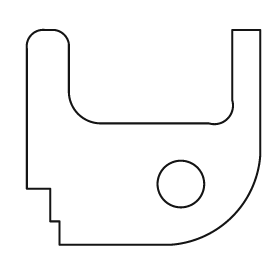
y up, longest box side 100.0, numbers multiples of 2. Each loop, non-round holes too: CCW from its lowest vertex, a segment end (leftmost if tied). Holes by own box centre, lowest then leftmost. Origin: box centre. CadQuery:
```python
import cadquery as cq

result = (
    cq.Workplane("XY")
    .moveTo(-36.0, -46.0)
    .lineTo(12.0, -46.0)
    .threePointArc((38.0, -34.0), (50.0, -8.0))
    .lineTo(50.0, 46.0)
    .lineTo(38.0, 46.0)
    .lineTo(38.0, 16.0)
    .threePointArc((36.0, 8.0), (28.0, 6.0))
    .lineTo(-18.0, 6.0)
    .threePointArc((-28.0, 10.0), (-32.0, 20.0))
    .lineTo(-32.0, 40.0)
    .threePointArc((-34.0, 44.0), (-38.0, 46.0))
    .lineTo(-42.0, 46.0)
    .threePointArc((-48.0, 44.0), (-50.0, 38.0))
    .lineTo(-50.0, -22.0)
    .lineTo(-40.0, -22.0)
    .lineTo(-40.0, -36.0)
    .lineTo(-36.0, -36.0)
    .close()
    .moveTo(16.0, -20.0)
    .circle(10.0)
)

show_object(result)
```